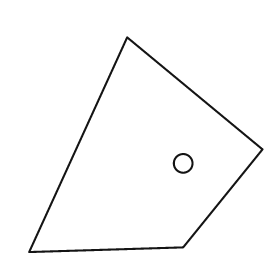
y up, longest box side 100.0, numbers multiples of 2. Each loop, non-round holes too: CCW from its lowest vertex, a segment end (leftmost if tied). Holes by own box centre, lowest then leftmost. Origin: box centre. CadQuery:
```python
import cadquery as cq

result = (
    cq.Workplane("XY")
    .moveTo(-50.0, -46.0)
    .lineTo(16.0, -44.0)
    .lineTo(50.0, -2.0)
    .lineTo(-8.0, 46.0)
    .close()
    .moveTo(16.0, -8.0)
    .circle(4.0)
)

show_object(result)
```